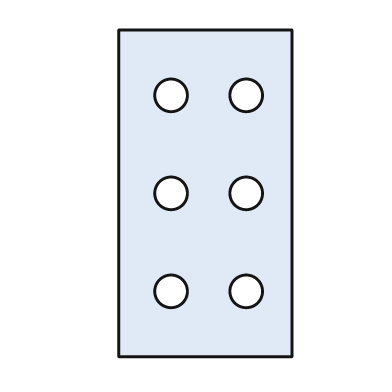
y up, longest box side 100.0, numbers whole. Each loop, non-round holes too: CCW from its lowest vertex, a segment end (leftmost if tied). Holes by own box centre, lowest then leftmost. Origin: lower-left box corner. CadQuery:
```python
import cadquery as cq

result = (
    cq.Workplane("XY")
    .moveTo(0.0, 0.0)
    .lineTo(53.0, 0.0)
    .lineTo(53.0, 100.0)
    .lineTo(0.0, 100.0)
    .close()
    .moveTo(16.0, 20.0)
    .circle(5.0)
    .moveTo(39.0, 20.0)
    .circle(5.0)
    .moveTo(16.0, 50.0)
    .circle(5.0)
    .moveTo(39.0, 50.0)
    .circle(5.0)
    .moveTo(16.0, 80.0)
    .circle(5.0)
    .moveTo(39.0, 80.0)
    .circle(5.0)
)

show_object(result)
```